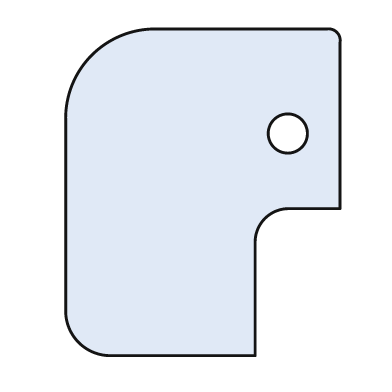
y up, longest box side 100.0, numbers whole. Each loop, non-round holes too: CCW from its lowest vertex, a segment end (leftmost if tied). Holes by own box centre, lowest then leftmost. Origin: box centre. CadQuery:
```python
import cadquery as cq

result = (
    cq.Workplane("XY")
    .moveTo(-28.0, -50.0)
    .lineTo(16.0, -50.0)
    .lineTo(16.0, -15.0)
    .threePointArc((19.0, -8.0), (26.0, -5.0))
    .lineTo(42.0, -5.0)
    .lineTo(42.0, 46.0)
    .threePointArc((41.0, 49.0), (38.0, 50.0))
    .lineTo(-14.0, 50.0)
    .threePointArc((-34.0, 42.0), (-42.0, 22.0))
    .lineTo(-42.0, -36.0)
    .threePointArc((-38.0, -46.0), (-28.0, -50.0))
    .close()
    .moveTo(26.0, 18.0)
    .circle(6.0)
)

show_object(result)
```